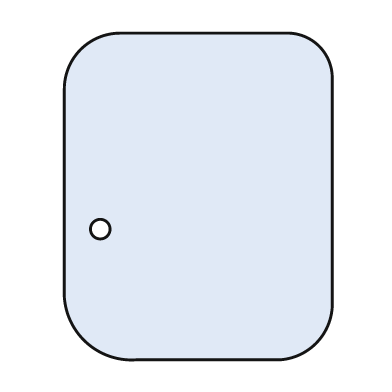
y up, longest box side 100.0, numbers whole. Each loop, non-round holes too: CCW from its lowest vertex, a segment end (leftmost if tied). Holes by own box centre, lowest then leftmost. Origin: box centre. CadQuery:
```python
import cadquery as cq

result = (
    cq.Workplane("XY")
    .moveTo(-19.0, -50.0)
    .lineTo(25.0, -50.0)
    .threePointArc((36.0, -45.0), (41.0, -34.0))
    .lineTo(41.0, 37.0)
    .threePointArc((37.0, 46.0), (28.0, 50.0))
    .lineTo(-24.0, 50.0)
    .threePointArc((-36.0, 45.0), (-41.0, 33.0))
    .lineTo(-41.0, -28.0)
    .threePointArc((-35.0, -44.0), (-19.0, -50.0))
    .close()
    .moveTo(-30.0, -10.0)
    .circle(3.0)
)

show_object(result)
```